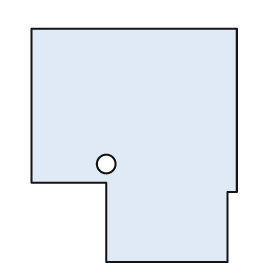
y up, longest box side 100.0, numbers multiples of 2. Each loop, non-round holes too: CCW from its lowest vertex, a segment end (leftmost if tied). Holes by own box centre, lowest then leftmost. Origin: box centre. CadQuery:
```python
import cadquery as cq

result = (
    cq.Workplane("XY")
    .moveTo(-12.0, -50.0)
    .lineTo(40.0, -50.0)
    .lineTo(40.0, -20.0)
    .lineTo(44.0, -20.0)
    .lineTo(44.0, 50.0)
    .lineTo(-44.0, 50.0)
    .lineTo(-44.0, -16.0)
    .lineTo(-12.0, -16.0)
    .close()
    .moveTo(-12.0, -8.0)
    .circle(4.0)
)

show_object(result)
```